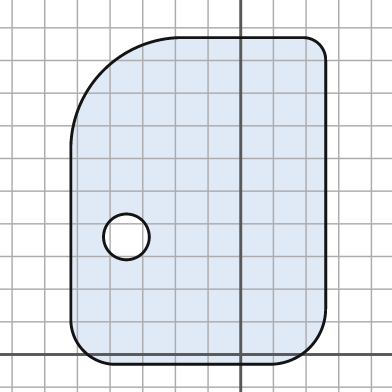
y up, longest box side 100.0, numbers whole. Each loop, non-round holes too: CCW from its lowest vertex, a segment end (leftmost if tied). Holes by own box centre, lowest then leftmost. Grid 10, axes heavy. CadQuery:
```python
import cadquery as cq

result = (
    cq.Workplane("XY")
    .moveTo(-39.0, -3.0)
    .lineTo(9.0, -3.0)
    .threePointArc((21.0, 2.0), (26.0, 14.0))
    .lineTo(26.0, 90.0)
    .threePointArc((24.0, 95.0), (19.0, 97.0))
    .lineTo(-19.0, 97.0)
    .threePointArc((-42.0, 87.0), (-52.0, 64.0))
    .lineTo(-52.0, 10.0)
    .threePointArc((-48.0, 1.0), (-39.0, -3.0))
    .close()
    .moveTo(-35.0, 36.0)
    .circle(7.0)
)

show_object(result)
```